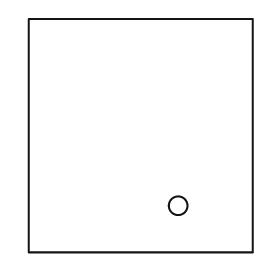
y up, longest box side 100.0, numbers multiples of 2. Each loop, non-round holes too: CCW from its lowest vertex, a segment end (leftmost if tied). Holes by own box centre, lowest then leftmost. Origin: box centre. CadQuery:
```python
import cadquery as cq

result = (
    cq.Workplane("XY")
    .moveTo(-48.0, -50.0)
    .lineTo(48.0, -50.0)
    .lineTo(48.0, 50.0)
    .lineTo(-48.0, 50.0)
    .close()
    .moveTo(16.0, -30.0)
    .circle(4.0)
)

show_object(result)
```